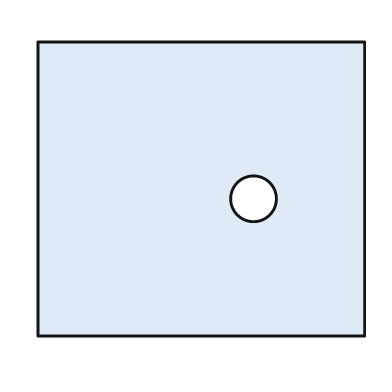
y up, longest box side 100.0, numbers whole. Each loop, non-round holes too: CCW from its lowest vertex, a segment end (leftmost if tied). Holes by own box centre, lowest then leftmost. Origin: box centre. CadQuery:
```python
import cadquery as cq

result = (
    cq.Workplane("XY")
    .moveTo(-50.0, -45.0)
    .lineTo(50.0, -45.0)
    .lineTo(50.0, 45.0)
    .lineTo(-50.0, 45.0)
    .close()
    .moveTo(16.0, -3.0)
    .circle(7.0)
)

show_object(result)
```